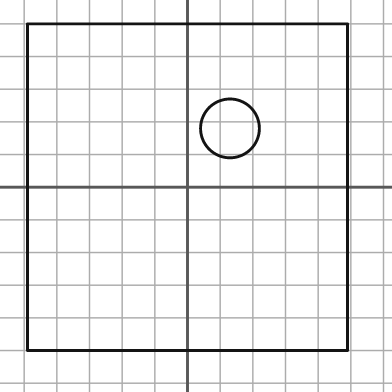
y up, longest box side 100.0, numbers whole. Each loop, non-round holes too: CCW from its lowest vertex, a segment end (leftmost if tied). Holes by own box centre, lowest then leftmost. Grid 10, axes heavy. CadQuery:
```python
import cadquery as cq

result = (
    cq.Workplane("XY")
    .moveTo(-49.0, -50.0)
    .lineTo(49.0, -50.0)
    .lineTo(49.0, 50.0)
    .lineTo(-49.0, 50.0)
    .close()
    .moveTo(13.0, 18.0)
    .circle(9.0)
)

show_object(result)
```